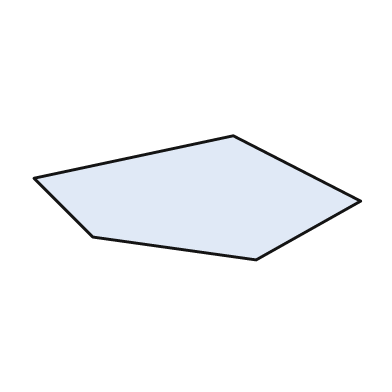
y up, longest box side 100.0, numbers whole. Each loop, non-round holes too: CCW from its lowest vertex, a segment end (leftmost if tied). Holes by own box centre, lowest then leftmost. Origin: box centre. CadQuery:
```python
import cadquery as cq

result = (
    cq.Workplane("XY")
    .moveTo(18.0, -19.0)
    .lineTo(50.0, -1.0)
    .lineTo(11.0, 19.0)
    .lineTo(-50.0, 6.0)
    .lineTo(-32.0, -12.0)
    .close()
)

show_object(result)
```